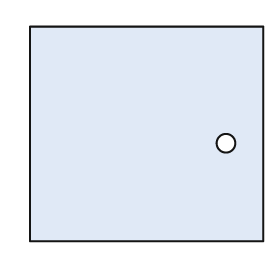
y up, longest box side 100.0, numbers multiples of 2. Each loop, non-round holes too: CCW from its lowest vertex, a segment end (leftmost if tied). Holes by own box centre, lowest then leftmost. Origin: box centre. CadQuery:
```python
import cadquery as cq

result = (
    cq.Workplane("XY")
    .moveTo(-50.0, -46.0)
    .lineTo(50.0, -46.0)
    .lineTo(50.0, 46.0)
    .lineTo(-50.0, 46.0)
    .close()
    .moveTo(34.0, -4.0)
    .circle(4.0)
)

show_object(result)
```